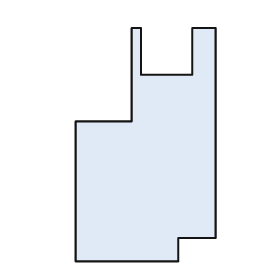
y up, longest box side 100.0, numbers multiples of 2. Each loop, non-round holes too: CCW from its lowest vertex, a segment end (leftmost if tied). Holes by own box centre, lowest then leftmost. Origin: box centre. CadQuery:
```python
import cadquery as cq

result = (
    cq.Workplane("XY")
    .moveTo(-30.0, -50.0)
    .lineTo(14.0, -50.0)
    .lineTo(14.0, -40.0)
    .lineTo(30.0, -40.0)
    .lineTo(30.0, 50.0)
    .lineTo(20.0, 50.0)
    .lineTo(20.0, 30.0)
    .lineTo(-2.0, 30.0)
    .lineTo(-2.0, 50.0)
    .lineTo(-6.0, 50.0)
    .lineTo(-6.0, 10.0)
    .lineTo(-30.0, 10.0)
    .close()
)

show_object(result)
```